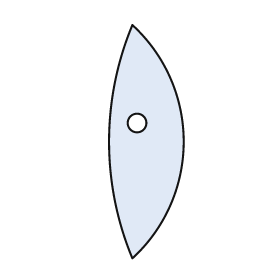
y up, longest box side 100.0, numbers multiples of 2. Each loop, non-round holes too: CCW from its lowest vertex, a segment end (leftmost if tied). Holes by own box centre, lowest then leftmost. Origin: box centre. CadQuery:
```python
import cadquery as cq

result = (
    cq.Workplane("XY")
    .moveTo(-6.0, -50.0)
    .threePointArc((16.0, 0.0), (-6.0, 50.0))
    .threePointArc((-16.0, 0.0), (-6.0, -50.0))
    .close()
    .moveTo(-4.0, 8.0)
    .circle(4.0)
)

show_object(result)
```